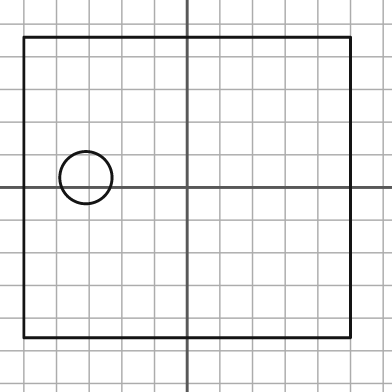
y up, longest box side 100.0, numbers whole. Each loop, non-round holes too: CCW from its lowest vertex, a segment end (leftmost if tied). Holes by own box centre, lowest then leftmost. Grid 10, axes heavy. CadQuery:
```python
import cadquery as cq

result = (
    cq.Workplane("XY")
    .moveTo(-50.0, -46.0)
    .lineTo(50.0, -46.0)
    .lineTo(50.0, 46.0)
    .lineTo(-50.0, 46.0)
    .close()
    .moveTo(-31.0, 3.0)
    .circle(8.0)
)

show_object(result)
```